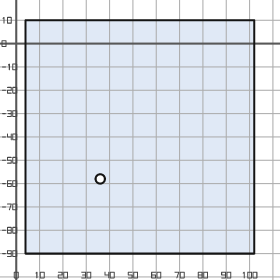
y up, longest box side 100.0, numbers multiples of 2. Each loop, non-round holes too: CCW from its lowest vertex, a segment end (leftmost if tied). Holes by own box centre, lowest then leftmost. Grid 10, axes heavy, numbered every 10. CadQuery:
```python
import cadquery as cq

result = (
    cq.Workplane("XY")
    .moveTo(4.0, -90.0)
    .lineTo(102.0, -90.0)
    .lineTo(102.0, 10.0)
    .lineTo(4.0, 10.0)
    .close()
    .moveTo(36.0, -58.0)
    .circle(2.0)
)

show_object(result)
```